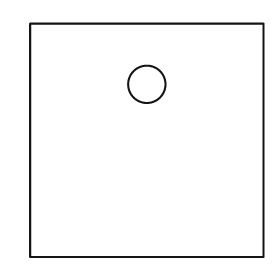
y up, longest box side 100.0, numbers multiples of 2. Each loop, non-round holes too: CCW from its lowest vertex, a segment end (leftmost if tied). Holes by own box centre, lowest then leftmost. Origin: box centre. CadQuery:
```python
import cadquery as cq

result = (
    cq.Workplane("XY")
    .moveTo(-50.0, -50.0)
    .lineTo(50.0, -50.0)
    .lineTo(50.0, 50.0)
    .lineTo(-50.0, 50.0)
    .close()
    .moveTo(0.0, 24.0)
    .circle(8.0)
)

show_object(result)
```